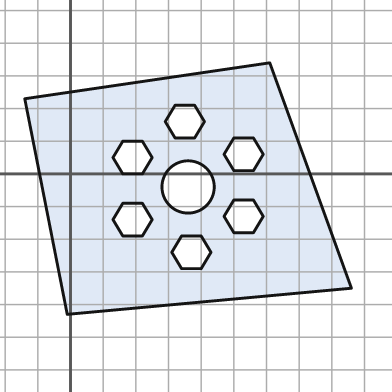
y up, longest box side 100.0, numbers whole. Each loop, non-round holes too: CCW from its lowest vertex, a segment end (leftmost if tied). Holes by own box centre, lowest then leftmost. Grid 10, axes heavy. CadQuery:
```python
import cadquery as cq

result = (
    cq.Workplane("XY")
    .moveTo(-1.0, -43.0)
    .lineTo(86.0, -35.0)
    .lineTo(61.0, 34.0)
    .lineTo(-14.0, 23.0)
    .close()
    .moveTo(34.0, -29.0)
    .lineTo(40.0, -29.0)
    .lineTo(43.0, -24.0)
    .lineTo(40.0, -19.0)
    .lineTo(34.0, -19.0)
    .lineTo(31.0, -24.0)
    .close()
    .moveTo(16.0, -19.0)
    .lineTo(22.0, -19.0)
    .lineTo(25.0, -14.0)
    .lineTo(22.0, -9.0)
    .lineTo(16.0, -9.0)
    .lineTo(13.0, -14.0)
    .close()
    .moveTo(50.0, -18.0)
    .lineTo(56.0, -18.0)
    .lineTo(59.0, -13.0)
    .lineTo(56.0, -8.0)
    .lineTo(50.0, -8.0)
    .lineTo(47.0, -13.0)
    .close()
    .moveTo(36.0, -4.0)
    .circle(8.0)
    .moveTo(16.0, 0.0)
    .lineTo(22.0, 0.0)
    .lineTo(25.0, 5.0)
    .lineTo(22.0, 10.0)
    .lineTo(16.0, 10.0)
    .lineTo(13.0, 5.0)
    .close()
    .moveTo(50.0, 1.0)
    .lineTo(56.0, 1.0)
    .lineTo(59.0, 6.0)
    .lineTo(56.0, 11.0)
    .lineTo(50.0, 11.0)
    .lineTo(47.0, 6.0)
    .close()
    .moveTo(32.0, 11.0)
    .lineTo(38.0, 11.0)
    .lineTo(41.0, 16.0)
    .lineTo(38.0, 21.0)
    .lineTo(32.0, 21.0)
    .lineTo(29.0, 16.0)
    .close()
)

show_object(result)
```